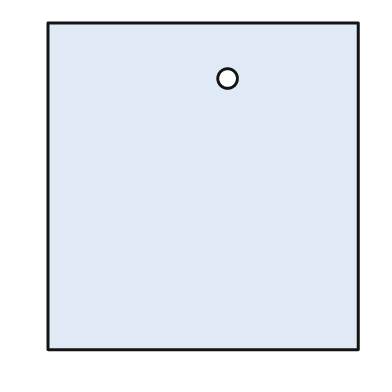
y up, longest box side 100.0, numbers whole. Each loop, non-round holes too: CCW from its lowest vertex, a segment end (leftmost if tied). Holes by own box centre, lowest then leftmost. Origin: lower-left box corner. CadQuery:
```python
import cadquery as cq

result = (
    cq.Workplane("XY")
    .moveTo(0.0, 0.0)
    .lineTo(95.0, 0.0)
    .lineTo(95.0, 100.0)
    .lineTo(0.0, 100.0)
    .close()
    .moveTo(55.0, 83.0)
    .circle(3.0)
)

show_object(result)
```